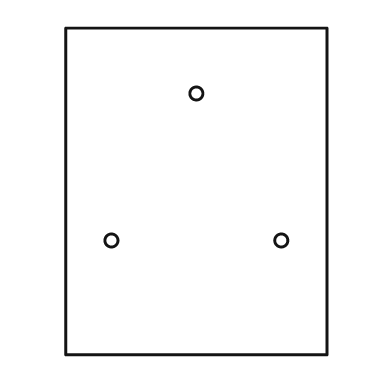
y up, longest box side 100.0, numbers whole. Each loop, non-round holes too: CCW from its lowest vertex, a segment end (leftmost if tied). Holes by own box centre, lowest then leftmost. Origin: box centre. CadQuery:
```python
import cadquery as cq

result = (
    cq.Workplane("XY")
    .moveTo(-40.0, -50.0)
    .lineTo(40.0, -50.0)
    .lineTo(40.0, 50.0)
    .lineTo(-40.0, 50.0)
    .close()
    .moveTo(-26.0, -15.0)
    .circle(2.0)
    .moveTo(26.0, -15.0)
    .circle(2.0)
    .moveTo(0.0, 30.0)
    .circle(2.0)
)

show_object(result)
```